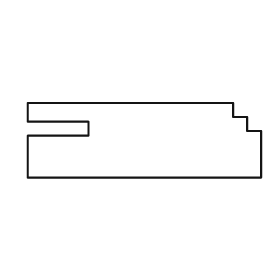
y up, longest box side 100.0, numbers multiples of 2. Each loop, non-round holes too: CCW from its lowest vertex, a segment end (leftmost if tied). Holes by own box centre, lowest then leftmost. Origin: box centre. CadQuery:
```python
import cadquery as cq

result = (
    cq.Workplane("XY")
    .moveTo(-50.0, -16.0)
    .lineTo(50.0, -16.0)
    .lineTo(50.0, 4.0)
    .lineTo(44.0, 4.0)
    .lineTo(44.0, 10.0)
    .lineTo(38.0, 10.0)
    .lineTo(38.0, 16.0)
    .lineTo(-50.0, 16.0)
    .lineTo(-50.0, 8.0)
    .lineTo(-24.0, 8.0)
    .lineTo(-24.0, 2.0)
    .lineTo(-50.0, 2.0)
    .close()
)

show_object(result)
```